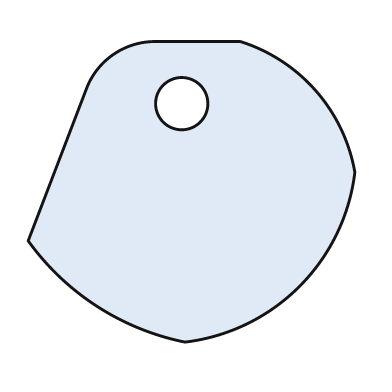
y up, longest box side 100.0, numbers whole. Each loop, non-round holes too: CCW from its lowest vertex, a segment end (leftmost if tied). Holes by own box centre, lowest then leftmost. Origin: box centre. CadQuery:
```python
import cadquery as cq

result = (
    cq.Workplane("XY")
    .moveTo(-2.0, -46.0)
    .threePointArc((33.0, -29.0), (50.0, 6.0))
    .threePointArc((38.0, 31.0), (15.0, 46.0))
    .lineTo(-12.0, 46.0)
    .threePointArc((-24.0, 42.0), (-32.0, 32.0))
    .lineTo(-50.0, -15.0)
    .threePointArc((-29.0, -35.0), (-2.0, -46.0))
    .close()
    .moveTo(-3.0, 27.0)
    .circle(8.0)
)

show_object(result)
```